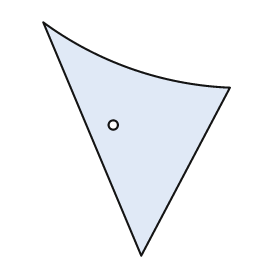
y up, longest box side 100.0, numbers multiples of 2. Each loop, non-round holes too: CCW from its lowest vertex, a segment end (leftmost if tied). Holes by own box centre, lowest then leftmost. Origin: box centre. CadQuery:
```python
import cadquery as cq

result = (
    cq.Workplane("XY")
    .moveTo(2.0, -50.0)
    .lineTo(40.0, 22.0)
    .threePointArc((-2.0, 30.0), (-40.0, 50.0))
    .close()
    .moveTo(-10.0, 6.0)
    .circle(2.0)
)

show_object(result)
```